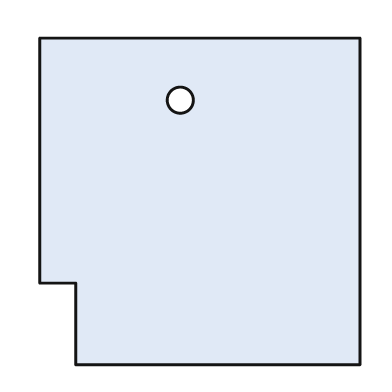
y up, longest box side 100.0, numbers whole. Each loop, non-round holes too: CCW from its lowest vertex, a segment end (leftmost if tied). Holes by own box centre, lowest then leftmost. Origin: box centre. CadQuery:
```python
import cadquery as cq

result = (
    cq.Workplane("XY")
    .moveTo(-38.0, -50.0)
    .lineTo(49.0, -50.0)
    .lineTo(49.0, 50.0)
    .lineTo(-49.0, 50.0)
    .lineTo(-49.0, -25.0)
    .lineTo(-38.0, -25.0)
    .close()
    .moveTo(-6.0, 31.0)
    .circle(4.0)
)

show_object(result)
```